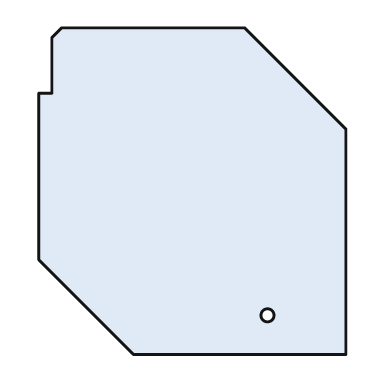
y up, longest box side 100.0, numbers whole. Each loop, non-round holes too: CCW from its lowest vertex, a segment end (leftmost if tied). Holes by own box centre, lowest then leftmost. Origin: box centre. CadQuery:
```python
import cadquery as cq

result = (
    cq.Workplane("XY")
    .moveTo(-18.0, -50.0)
    .lineTo(47.0, -50.0)
    .lineTo(47.0, 19.0)
    .lineTo(16.0, 50.0)
    .lineTo(-40.0, 50.0)
    .lineTo(-43.0, 47.0)
    .lineTo(-43.0, 30.0)
    .lineTo(-47.0, 30.0)
    .lineTo(-47.0, -21.0)
    .close()
    .moveTo(23.0, -38.0)
    .circle(2.0)
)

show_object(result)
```